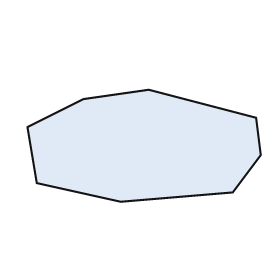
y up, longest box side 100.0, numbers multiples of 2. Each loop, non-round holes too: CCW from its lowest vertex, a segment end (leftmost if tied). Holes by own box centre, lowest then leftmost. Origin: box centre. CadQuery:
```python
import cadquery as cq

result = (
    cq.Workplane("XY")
    .moveTo(-10.0, -24.0)
    .lineTo(38.0, -20.0)
    .lineTo(50.0, -4.0)
    .lineTo(48.0, 12.0)
    .lineTo(2.0, 24.0)
    .lineTo(-26.0, 20.0)
    .lineTo(-50.0, 8.0)
    .lineTo(-46.0, -16.0)
    .close()
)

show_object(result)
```